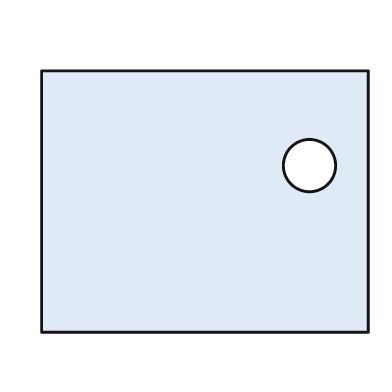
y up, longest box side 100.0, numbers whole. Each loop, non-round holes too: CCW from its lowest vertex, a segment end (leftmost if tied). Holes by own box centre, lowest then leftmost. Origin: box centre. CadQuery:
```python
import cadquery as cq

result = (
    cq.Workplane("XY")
    .moveTo(-50.0, -40.0)
    .lineTo(50.0, -40.0)
    .lineTo(50.0, 40.0)
    .lineTo(-50.0, 40.0)
    .close()
    .moveTo(32.0, 11.0)
    .circle(8.0)
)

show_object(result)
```